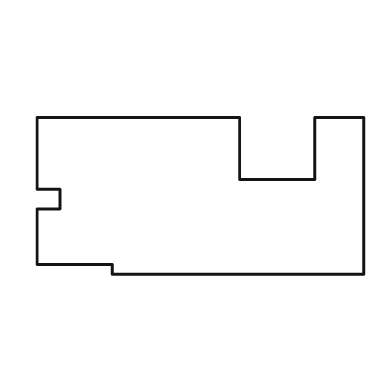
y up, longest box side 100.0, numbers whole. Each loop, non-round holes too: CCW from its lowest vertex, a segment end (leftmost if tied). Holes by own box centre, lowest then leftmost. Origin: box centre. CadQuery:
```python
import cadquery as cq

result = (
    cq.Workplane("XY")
    .moveTo(-27.0, -24.0)
    .lineTo(50.0, -24.0)
    .lineTo(50.0, 24.0)
    .lineTo(35.0, 24.0)
    .lineTo(35.0, 5.0)
    .lineTo(12.0, 5.0)
    .lineTo(12.0, 24.0)
    .lineTo(-50.0, 24.0)
    .lineTo(-50.0, 2.0)
    .lineTo(-43.0, 2.0)
    .lineTo(-43.0, -4.0)
    .lineTo(-50.0, -4.0)
    .lineTo(-50.0, -21.0)
    .lineTo(-27.0, -21.0)
    .close()
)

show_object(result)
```